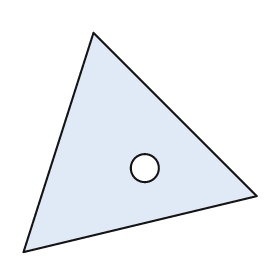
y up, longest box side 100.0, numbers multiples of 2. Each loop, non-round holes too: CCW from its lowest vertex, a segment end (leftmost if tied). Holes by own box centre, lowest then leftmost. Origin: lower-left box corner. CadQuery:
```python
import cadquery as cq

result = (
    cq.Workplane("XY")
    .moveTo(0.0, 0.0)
    .lineTo(100.0, 24.0)
    .lineTo(30.0, 94.0)
    .close()
    .moveTo(52.0, 36.0)
    .circle(6.0)
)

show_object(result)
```